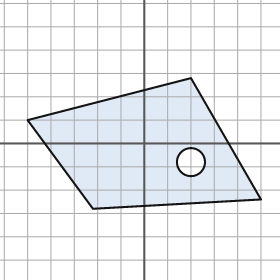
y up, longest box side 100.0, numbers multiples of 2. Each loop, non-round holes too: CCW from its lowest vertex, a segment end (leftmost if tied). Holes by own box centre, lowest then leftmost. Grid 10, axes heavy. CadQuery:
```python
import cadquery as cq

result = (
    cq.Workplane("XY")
    .moveTo(-22.0, -28.0)
    .lineTo(50.0, -24.0)
    .lineTo(20.0, 28.0)
    .lineTo(-50.0, 10.0)
    .close()
    .moveTo(20.0, -8.0)
    .circle(6.0)
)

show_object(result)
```